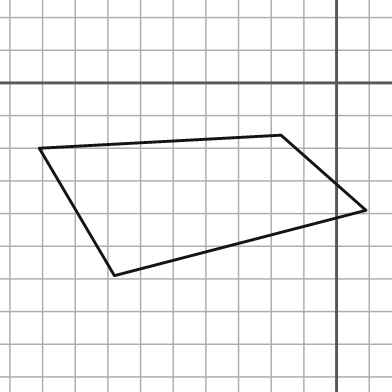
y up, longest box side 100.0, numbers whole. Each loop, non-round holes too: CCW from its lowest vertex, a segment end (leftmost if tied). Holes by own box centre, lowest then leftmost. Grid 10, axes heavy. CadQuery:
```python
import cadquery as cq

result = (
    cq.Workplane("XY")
    .moveTo(-68.0, -59.0)
    .lineTo(9.0, -39.0)
    .lineTo(-17.0, -16.0)
    .lineTo(-91.0, -20.0)
    .close()
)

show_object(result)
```